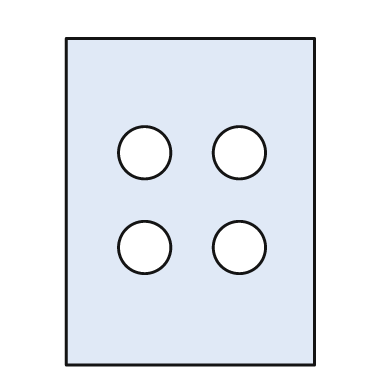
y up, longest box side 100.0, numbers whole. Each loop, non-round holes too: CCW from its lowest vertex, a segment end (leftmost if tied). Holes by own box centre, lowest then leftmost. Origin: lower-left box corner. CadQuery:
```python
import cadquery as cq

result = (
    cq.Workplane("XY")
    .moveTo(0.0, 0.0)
    .lineTo(76.0, 0.0)
    .lineTo(76.0, 100.0)
    .lineTo(0.0, 100.0)
    .close()
    .moveTo(24.0, 36.0)
    .circle(8.0)
    .moveTo(53.0, 36.0)
    .circle(8.0)
    .moveTo(24.0, 65.0)
    .circle(8.0)
    .moveTo(53.0, 65.0)
    .circle(8.0)
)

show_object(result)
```